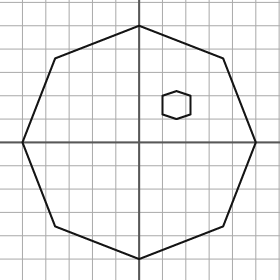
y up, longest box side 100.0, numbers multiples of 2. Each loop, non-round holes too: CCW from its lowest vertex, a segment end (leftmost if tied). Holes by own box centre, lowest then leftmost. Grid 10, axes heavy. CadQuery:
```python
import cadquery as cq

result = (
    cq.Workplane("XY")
    .moveTo(0.0, -50.0)
    .lineTo(36.0, -36.0)
    .lineTo(50.0, 0.0)
    .lineTo(36.0, 36.0)
    .lineTo(0.0, 50.0)
    .lineTo(-36.0, 36.0)
    .lineTo(-50.0, 0.0)
    .lineTo(-36.0, -36.0)
    .close()
    .moveTo(16.0, 10.0)
    .lineTo(22.0, 12.0)
    .lineTo(22.0, 20.0)
    .lineTo(16.0, 22.0)
    .lineTo(10.0, 20.0)
    .lineTo(10.0, 12.0)
    .close()
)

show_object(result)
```